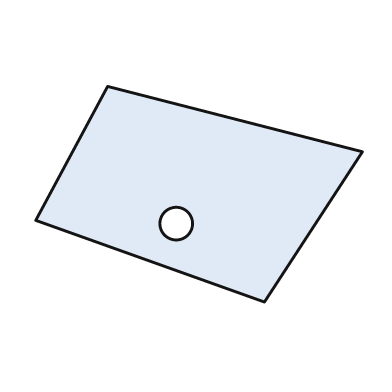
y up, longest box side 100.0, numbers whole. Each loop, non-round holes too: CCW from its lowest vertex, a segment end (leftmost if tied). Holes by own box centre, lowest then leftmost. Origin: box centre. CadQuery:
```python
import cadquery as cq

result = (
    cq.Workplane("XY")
    .moveTo(20.0, -33.0)
    .lineTo(50.0, 13.0)
    .lineTo(-28.0, 33.0)
    .lineTo(-50.0, -8.0)
    .close()
    .moveTo(-7.0, -9.0)
    .circle(5.0)
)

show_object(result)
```